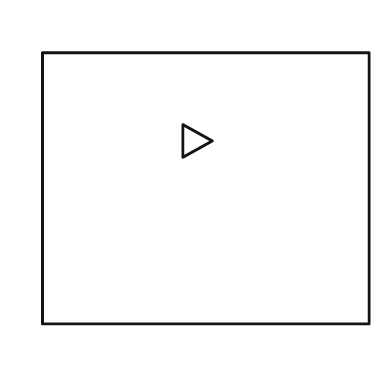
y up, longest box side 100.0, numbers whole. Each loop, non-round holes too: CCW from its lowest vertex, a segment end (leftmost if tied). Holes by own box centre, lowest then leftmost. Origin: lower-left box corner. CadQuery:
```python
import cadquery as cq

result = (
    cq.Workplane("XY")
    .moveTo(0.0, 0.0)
    .lineTo(100.0, 0.0)
    .lineTo(100.0, 83.0)
    .lineTo(0.0, 83.0)
    .close()
    .moveTo(43.0, 51.0)
    .lineTo(52.0, 56.0)
    .lineTo(43.0, 61.0)
    .close()
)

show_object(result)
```